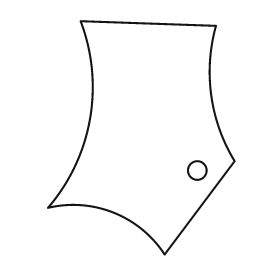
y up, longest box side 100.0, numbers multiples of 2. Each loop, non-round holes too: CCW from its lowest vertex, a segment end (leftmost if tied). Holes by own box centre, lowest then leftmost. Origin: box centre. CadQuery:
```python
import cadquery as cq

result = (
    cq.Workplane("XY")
    .moveTo(10.0, -50.0)
    .lineTo(40.0, -10.0)
    .threePointArc((30.0, 18.0), (32.0, 48.0))
    .lineTo(-26.0, 50.0)
    .threePointArc((-22.0, 8.0), (-40.0, -30.0))
    .threePointArc((-12.0, -32.0), (10.0, -50.0))
    .close()
    .moveTo(24.0, -14.0)
    .circle(4.0)
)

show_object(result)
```